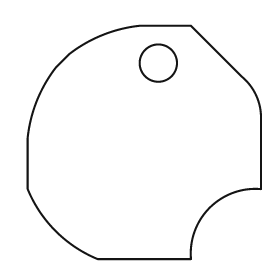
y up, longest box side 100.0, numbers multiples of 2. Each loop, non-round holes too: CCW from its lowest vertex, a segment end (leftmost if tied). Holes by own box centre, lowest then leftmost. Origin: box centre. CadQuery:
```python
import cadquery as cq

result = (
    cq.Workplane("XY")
    .moveTo(-20.0, -50.0)
    .lineTo(20.0, -50.0)
    .threePointArc((28.0, -28.0), (50.0, -20.0))
    .lineTo(50.0, 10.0)
    .threePointArc((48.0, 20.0), (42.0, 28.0))
    .lineTo(20.0, 50.0)
    .lineTo(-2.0, 50.0)
    .threePointArc((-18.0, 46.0), (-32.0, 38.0))
    .lineTo(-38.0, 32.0)
    .threePointArc((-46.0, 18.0), (-50.0, 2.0))
    .lineTo(-50.0, -20.0)
    .threePointArc((-38.0, -38.0), (-20.0, -50.0))
    .close()
    .moveTo(6.0, 34.0)
    .circle(8.0)
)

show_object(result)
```